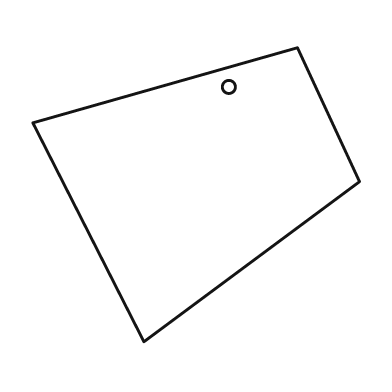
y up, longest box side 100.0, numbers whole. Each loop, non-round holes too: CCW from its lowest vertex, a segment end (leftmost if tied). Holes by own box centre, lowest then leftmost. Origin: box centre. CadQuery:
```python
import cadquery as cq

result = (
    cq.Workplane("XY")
    .moveTo(-16.0, -45.0)
    .lineTo(50.0, 4.0)
    .lineTo(31.0, 45.0)
    .lineTo(-50.0, 22.0)
    .close()
    .moveTo(10.0, 33.0)
    .circle(2.0)
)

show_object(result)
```